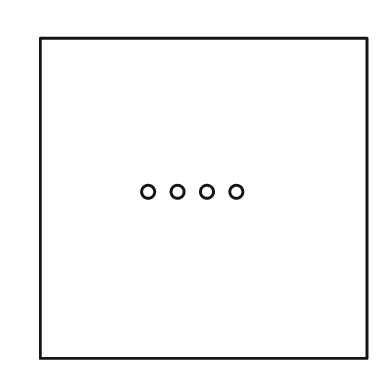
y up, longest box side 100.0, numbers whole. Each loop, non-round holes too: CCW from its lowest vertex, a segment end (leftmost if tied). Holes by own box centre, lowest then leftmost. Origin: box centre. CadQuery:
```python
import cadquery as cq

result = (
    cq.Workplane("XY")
    .moveTo(-50.0, -49.0)
    .lineTo(50.0, -49.0)
    .lineTo(50.0, 49.0)
    .lineTo(-50.0, 49.0)
    .close()
    .moveTo(-17.0, 2.0)
    .circle(2.0)
    .moveTo(-8.0, 2.0)
    .circle(2.0)
    .moveTo(1.0, 2.0)
    .circle(2.0)
    .moveTo(10.0, 2.0)
    .circle(2.0)
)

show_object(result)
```